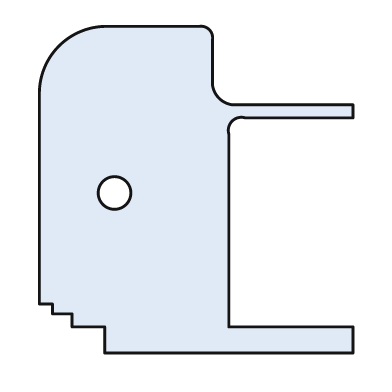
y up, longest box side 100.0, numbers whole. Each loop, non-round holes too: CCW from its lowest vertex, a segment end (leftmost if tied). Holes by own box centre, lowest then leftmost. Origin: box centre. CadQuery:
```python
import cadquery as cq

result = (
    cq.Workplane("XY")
    .moveTo(-28.0, -50.0)
    .lineTo(48.0, -50.0)
    .lineTo(48.0, -42.0)
    .lineTo(10.0, -42.0)
    .lineTo(10.0, 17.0)
    .threePointArc((11.0, 21.0), (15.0, 22.0))
    .lineTo(48.0, 22.0)
    .lineTo(48.0, 26.0)
    .lineTo(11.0, 26.0)
    .threePointArc((7.0, 28.0), (5.0, 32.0))
    .lineTo(5.0, 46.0)
    .threePointArc((4.0, 49.0), (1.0, 50.0))
    .lineTo(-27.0, 50.0)
    .threePointArc((-42.0, 44.0), (-48.0, 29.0))
    .lineTo(-48.0, -35.0)
    .lineTo(-44.0, -35.0)
    .lineTo(-44.0, -38.0)
    .lineTo(-38.0, -38.0)
    .lineTo(-38.0, -42.0)
    .lineTo(-28.0, -42.0)
    .close()
    .moveTo(-25.0, -1.0)
    .circle(5.0)
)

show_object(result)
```